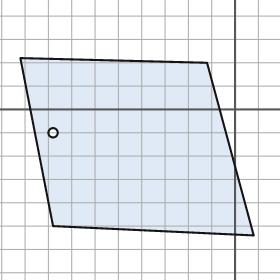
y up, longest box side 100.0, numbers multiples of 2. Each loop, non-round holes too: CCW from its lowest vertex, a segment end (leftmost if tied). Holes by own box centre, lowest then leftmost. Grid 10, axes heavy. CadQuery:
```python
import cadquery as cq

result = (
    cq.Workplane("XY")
    .moveTo(8.0, -54.0)
    .lineTo(-12.0, 20.0)
    .lineTo(-92.0, 22.0)
    .lineTo(-78.0, -50.0)
    .close()
    .moveTo(-78.0, -10.0)
    .circle(2.0)
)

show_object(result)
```